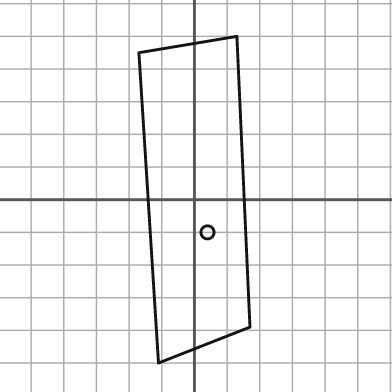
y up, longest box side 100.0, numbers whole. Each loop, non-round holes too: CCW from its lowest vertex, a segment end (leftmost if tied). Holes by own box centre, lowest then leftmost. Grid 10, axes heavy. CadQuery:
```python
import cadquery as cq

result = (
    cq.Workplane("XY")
    .moveTo(-11.0, -50.0)
    .lineTo(17.0, -39.0)
    .lineTo(13.0, 50.0)
    .lineTo(-17.0, 45.0)
    .close()
    .moveTo(4.0, -10.0)
    .circle(2.0)
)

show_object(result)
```